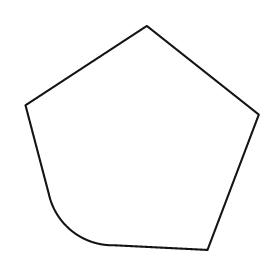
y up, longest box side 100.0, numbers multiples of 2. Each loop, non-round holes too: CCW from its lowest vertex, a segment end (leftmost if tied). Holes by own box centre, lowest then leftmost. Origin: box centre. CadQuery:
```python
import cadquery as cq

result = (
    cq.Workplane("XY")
    .moveTo(28.0, -48.0)
    .lineTo(50.0, 10.0)
    .lineTo(2.0, 48.0)
    .lineTo(-50.0, 14.0)
    .lineTo(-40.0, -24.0)
    .threePointArc((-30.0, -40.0), (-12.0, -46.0))
    .close()
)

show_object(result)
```